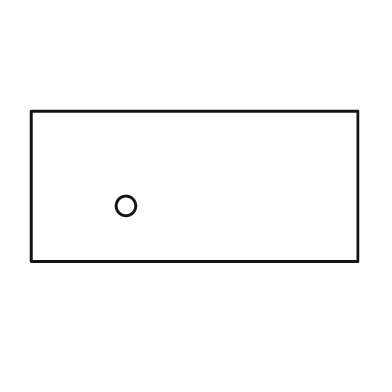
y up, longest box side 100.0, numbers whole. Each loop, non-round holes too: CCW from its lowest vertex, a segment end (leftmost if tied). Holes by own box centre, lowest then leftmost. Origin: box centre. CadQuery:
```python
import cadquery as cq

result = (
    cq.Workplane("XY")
    .moveTo(-50.0, -23.0)
    .lineTo(50.0, -23.0)
    .lineTo(50.0, 23.0)
    .lineTo(-50.0, 23.0)
    .close()
    .moveTo(-21.0, -6.0)
    .circle(3.0)
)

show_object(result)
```